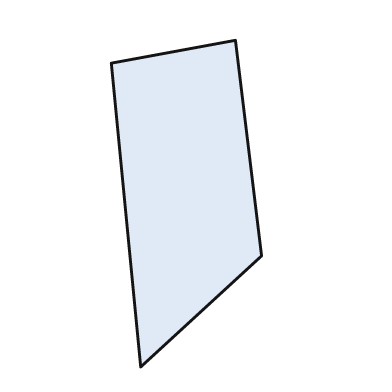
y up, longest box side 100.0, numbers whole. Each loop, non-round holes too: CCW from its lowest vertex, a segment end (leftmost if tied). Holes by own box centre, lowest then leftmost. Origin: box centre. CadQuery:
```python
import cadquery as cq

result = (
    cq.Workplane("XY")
    .moveTo(-14.0, -50.0)
    .lineTo(23.0, -16.0)
    .lineTo(15.0, 50.0)
    .lineTo(-23.0, 43.0)
    .close()
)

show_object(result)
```